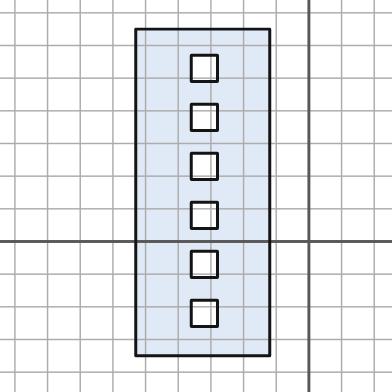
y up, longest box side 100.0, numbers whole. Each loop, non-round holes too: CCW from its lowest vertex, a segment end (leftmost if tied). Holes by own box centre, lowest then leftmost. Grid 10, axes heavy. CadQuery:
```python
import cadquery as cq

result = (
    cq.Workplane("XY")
    .moveTo(-53.0, -35.0)
    .lineTo(-12.0, -35.0)
    .lineTo(-12.0, 65.0)
    .lineTo(-53.0, 65.0)
    .close()
    .moveTo(-36.0, -26.0)
    .lineTo(-28.0, -26.0)
    .lineTo(-28.0, -18.0)
    .lineTo(-36.0, -18.0)
    .close()
    .moveTo(-36.0, -11.0)
    .lineTo(-28.0, -11.0)
    .lineTo(-28.0, -3.0)
    .lineTo(-36.0, -3.0)
    .close()
    .moveTo(-36.0, 4.0)
    .lineTo(-28.0, 4.0)
    .lineTo(-28.0, 12.0)
    .lineTo(-36.0, 12.0)
    .close()
    .moveTo(-36.0, 19.0)
    .lineTo(-28.0, 19.0)
    .lineTo(-28.0, 27.0)
    .lineTo(-36.0, 27.0)
    .close()
    .moveTo(-36.0, 34.0)
    .lineTo(-28.0, 34.0)
    .lineTo(-28.0, 42.0)
    .lineTo(-36.0, 42.0)
    .close()
    .moveTo(-36.0, 49.0)
    .lineTo(-28.0, 49.0)
    .lineTo(-28.0, 57.0)
    .lineTo(-36.0, 57.0)
    .close()
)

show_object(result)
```